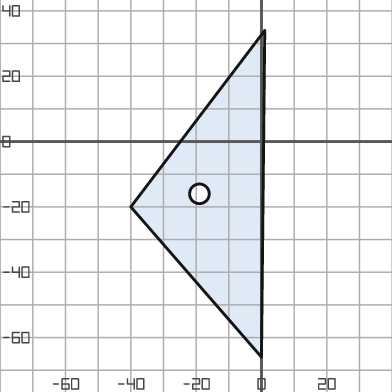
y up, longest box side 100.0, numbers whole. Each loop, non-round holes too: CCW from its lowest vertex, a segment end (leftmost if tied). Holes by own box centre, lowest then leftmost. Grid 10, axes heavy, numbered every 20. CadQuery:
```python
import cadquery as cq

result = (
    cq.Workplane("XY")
    .moveTo(0.0, -66.0)
    .lineTo(1.0, 34.0)
    .lineTo(-40.0, -20.0)
    .close()
    .moveTo(-19.0, -16.0)
    .circle(3.0)
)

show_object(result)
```